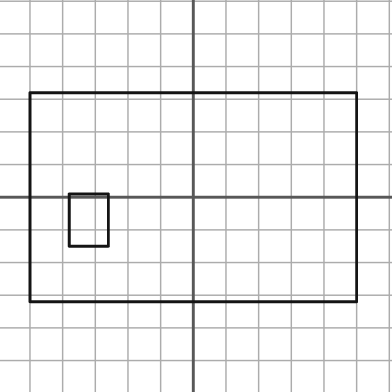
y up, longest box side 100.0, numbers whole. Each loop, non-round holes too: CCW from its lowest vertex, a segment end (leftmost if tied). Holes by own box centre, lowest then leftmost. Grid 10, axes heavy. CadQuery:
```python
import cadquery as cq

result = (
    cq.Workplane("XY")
    .moveTo(-50.0, -32.0)
    .lineTo(50.0, -32.0)
    .lineTo(50.0, 32.0)
    .lineTo(-50.0, 32.0)
    .close()
    .moveTo(-38.0, -15.0)
    .lineTo(-26.0, -15.0)
    .lineTo(-26.0, 1.0)
    .lineTo(-38.0, 1.0)
    .close()
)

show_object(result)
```